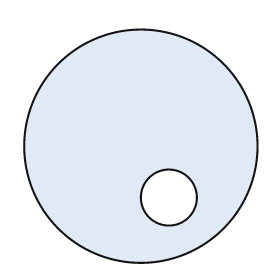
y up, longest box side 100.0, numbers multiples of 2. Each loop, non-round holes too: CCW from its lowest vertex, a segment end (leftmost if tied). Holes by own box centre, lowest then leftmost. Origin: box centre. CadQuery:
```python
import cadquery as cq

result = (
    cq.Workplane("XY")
    .moveTo(0.0, 0.0)
    .circle(50.0)
    .moveTo(12.0, -22.0)
    .circle(12.0)
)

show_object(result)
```